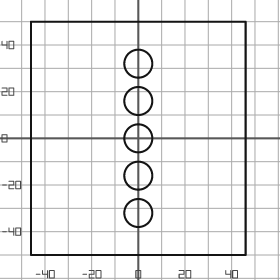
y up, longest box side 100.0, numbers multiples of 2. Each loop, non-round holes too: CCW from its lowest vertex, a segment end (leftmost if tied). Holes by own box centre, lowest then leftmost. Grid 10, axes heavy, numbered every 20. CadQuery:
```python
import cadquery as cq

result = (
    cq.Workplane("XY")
    .moveTo(-46.0, -50.0)
    .lineTo(46.0, -50.0)
    .lineTo(46.0, 50.0)
    .lineTo(-46.0, 50.0)
    .close()
    .moveTo(0.0, -32.0)
    .circle(6.0)
    .moveTo(0.0, -16.0)
    .circle(6.0)
    .moveTo(0.0, 0.0)
    .circle(6.0)
    .moveTo(0.0, 16.0)
    .circle(6.0)
    .moveTo(0.0, 32.0)
    .circle(6.0)
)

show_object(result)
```